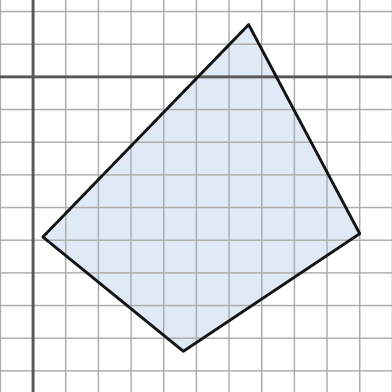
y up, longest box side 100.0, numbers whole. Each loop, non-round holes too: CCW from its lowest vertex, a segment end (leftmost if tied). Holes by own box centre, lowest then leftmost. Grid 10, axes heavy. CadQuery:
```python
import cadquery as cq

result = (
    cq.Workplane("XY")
    .moveTo(46.0, -84.0)
    .lineTo(100.0, -48.0)
    .lineTo(66.0, 16.0)
    .lineTo(3.0, -49.0)
    .close()
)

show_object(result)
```